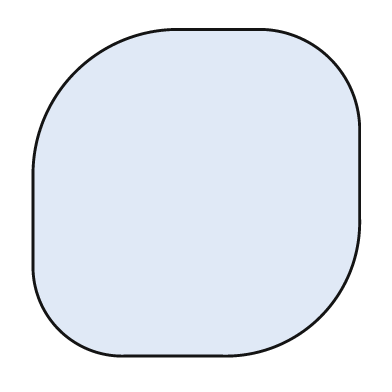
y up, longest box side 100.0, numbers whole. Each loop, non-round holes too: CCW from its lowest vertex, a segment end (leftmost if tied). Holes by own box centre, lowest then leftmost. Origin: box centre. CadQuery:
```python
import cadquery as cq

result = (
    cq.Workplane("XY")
    .moveTo(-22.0, -50.0)
    .lineTo(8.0, -50.0)
    .threePointArc((38.0, -38.0), (50.0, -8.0))
    .lineTo(50.0, 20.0)
    .threePointArc((41.0, 41.0), (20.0, 50.0))
    .lineTo(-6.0, 50.0)
    .threePointArc((-37.0, 37.0), (-50.0, 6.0))
    .lineTo(-50.0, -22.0)
    .threePointArc((-42.0, -42.0), (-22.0, -50.0))
    .close()
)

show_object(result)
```